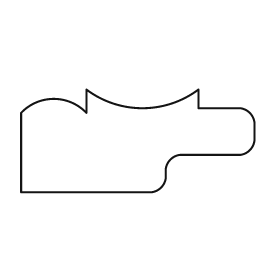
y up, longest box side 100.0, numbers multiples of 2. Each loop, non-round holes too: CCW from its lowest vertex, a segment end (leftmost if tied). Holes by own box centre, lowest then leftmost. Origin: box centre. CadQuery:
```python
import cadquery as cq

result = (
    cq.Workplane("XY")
    .moveTo(-50.0, -22.0)
    .lineTo(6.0, -22.0)
    .threePointArc((10.0, -20.0), (12.0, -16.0))
    .lineTo(12.0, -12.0)
    .threePointArc((14.0, -8.0), (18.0, -6.0))
    .lineTo(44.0, -6.0)
    .threePointArc((48.0, -4.0), (50.0, 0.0))
    .lineTo(50.0, 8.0)
    .threePointArc((48.0, 12.0), (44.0, 14.0))
    .lineTo(26.0, 14.0)
    .lineTo(26.0, 22.0)
    .threePointArc((2.0, 14.0), (-22.0, 22.0))
    .lineTo(-22.0, 12.0)
    .threePointArc((-36.0, 18.0), (-50.0, 12.0))
    .close()
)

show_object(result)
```